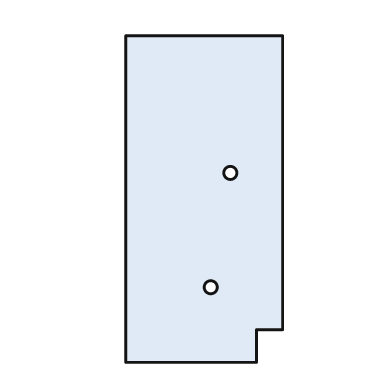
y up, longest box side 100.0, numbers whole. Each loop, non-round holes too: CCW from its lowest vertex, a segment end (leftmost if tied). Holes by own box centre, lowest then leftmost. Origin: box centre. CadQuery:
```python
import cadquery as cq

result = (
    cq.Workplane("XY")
    .moveTo(-24.0, -50.0)
    .lineTo(16.0, -50.0)
    .lineTo(16.0, -40.0)
    .lineTo(24.0, -40.0)
    .lineTo(24.0, 50.0)
    .lineTo(-24.0, 50.0)
    .close()
    .moveTo(2.0, -27.0)
    .circle(2.0)
    .moveTo(8.0, 8.0)
    .circle(2.0)
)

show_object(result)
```